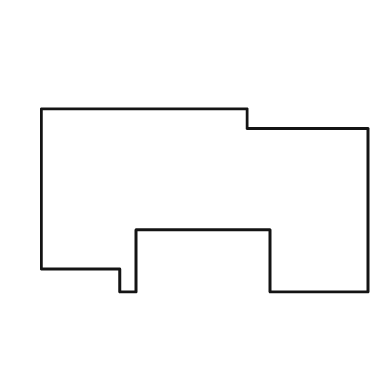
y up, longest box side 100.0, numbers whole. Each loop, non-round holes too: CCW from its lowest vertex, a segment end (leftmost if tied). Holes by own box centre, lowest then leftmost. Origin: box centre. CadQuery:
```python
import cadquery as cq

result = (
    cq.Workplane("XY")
    .moveTo(-26.0, -28.0)
    .lineTo(-21.0, -28.0)
    .lineTo(-21.0, -9.0)
    .lineTo(20.0, -9.0)
    .lineTo(20.0, -28.0)
    .lineTo(50.0, -28.0)
    .lineTo(50.0, 22.0)
    .lineTo(13.0, 22.0)
    .lineTo(13.0, 28.0)
    .lineTo(-50.0, 28.0)
    .lineTo(-50.0, -21.0)
    .lineTo(-26.0, -21.0)
    .close()
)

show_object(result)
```